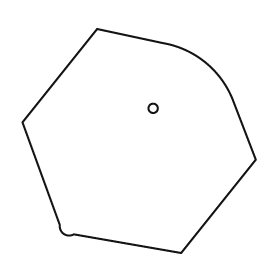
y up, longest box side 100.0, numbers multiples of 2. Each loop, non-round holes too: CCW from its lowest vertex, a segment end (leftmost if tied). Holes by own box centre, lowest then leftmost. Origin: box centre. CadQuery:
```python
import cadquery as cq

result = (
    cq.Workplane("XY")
    .moveTo(18.0, -48.0)
    .lineTo(50.0, -8.0)
    .lineTo(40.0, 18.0)
    .threePointArc((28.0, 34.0), (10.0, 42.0))
    .lineTo(-18.0, 48.0)
    .lineTo(-50.0, 8.0)
    .lineTo(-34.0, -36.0)
    .threePointArc((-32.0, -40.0), (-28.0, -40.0))
    .close()
    .moveTo(6.0, 14.0)
    .circle(2.0)
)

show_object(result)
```